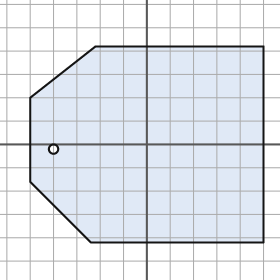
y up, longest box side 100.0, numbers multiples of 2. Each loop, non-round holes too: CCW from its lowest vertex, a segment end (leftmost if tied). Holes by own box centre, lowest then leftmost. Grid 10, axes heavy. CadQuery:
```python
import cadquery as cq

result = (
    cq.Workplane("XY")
    .moveTo(-24.0, -42.0)
    .lineTo(50.0, -42.0)
    .lineTo(50.0, 42.0)
    .lineTo(-22.0, 42.0)
    .lineTo(-50.0, 20.0)
    .lineTo(-50.0, -16.0)
    .close()
    .moveTo(-40.0, -2.0)
    .circle(2.0)
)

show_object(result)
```